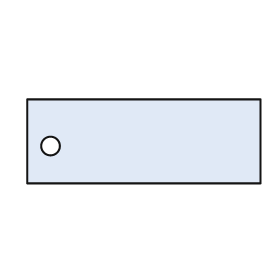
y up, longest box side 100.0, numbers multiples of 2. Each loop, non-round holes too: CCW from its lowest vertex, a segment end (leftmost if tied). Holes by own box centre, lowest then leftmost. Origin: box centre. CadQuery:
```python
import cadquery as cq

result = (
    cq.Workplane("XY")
    .moveTo(-50.0, -18.0)
    .lineTo(50.0, -18.0)
    .lineTo(50.0, 18.0)
    .lineTo(-50.0, 18.0)
    .close()
    .moveTo(-40.0, -2.0)
    .circle(4.0)
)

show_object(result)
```